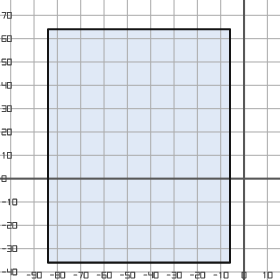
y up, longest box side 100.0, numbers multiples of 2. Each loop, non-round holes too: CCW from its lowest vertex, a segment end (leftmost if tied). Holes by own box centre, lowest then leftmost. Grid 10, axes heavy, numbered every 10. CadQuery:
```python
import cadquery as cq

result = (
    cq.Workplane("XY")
    .moveTo(-84.0, -36.0)
    .lineTo(-6.0, -36.0)
    .lineTo(-6.0, 64.0)
    .lineTo(-84.0, 64.0)
    .close()
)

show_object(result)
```